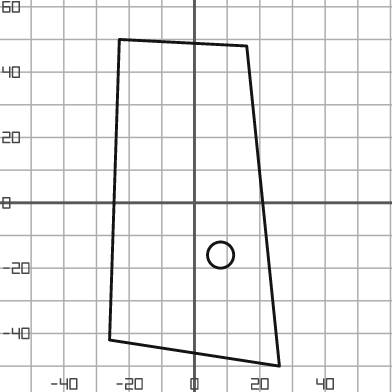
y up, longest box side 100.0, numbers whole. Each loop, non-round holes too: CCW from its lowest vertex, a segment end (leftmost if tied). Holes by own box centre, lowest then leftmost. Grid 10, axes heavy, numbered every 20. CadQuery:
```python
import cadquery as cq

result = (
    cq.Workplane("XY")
    .moveTo(26.0, -50.0)
    .lineTo(16.0, 48.0)
    .lineTo(-23.0, 50.0)
    .lineTo(-26.0, -42.0)
    .close()
    .moveTo(8.0, -16.0)
    .circle(4.0)
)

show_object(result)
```